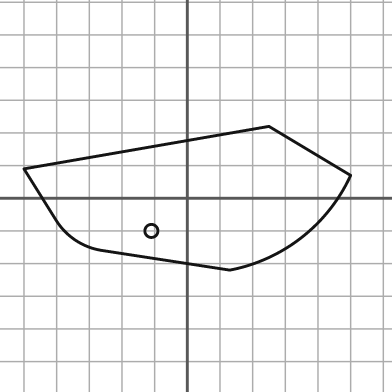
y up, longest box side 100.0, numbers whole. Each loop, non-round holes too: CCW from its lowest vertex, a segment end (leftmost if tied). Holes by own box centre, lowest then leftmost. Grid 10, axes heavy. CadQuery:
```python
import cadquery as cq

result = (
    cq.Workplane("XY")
    .moveTo(13.0, -22.0)
    .threePointArc((35.0, -12.0), (50.0, 7.0))
    .lineTo(25.0, 22.0)
    .lineTo(-50.0, 9.0)
    .lineTo(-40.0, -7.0)
    .threePointArc((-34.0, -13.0), (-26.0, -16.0))
    .close()
    .moveTo(-11.0, -10.0)
    .circle(2.0)
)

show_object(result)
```